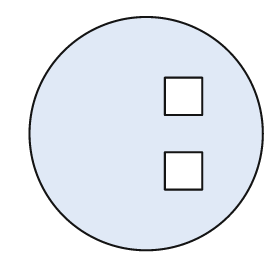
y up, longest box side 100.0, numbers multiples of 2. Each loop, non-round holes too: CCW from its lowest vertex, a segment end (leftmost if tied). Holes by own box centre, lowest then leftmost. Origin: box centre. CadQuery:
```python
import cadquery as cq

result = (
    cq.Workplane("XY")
    .moveTo(0.0, 0.0)
    .circle(50.0)
    .moveTo(8.0, -24.0)
    .lineTo(24.0, -24.0)
    .lineTo(24.0, -8.0)
    .lineTo(8.0, -8.0)
    .close()
    .moveTo(8.0, 8.0)
    .lineTo(24.0, 8.0)
    .lineTo(24.0, 24.0)
    .lineTo(8.0, 24.0)
    .close()
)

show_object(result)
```